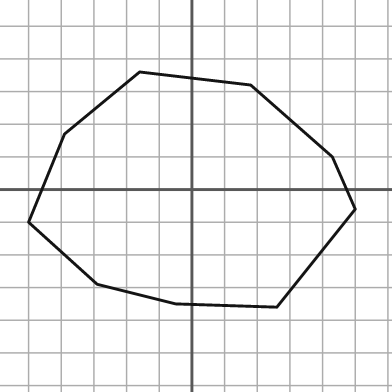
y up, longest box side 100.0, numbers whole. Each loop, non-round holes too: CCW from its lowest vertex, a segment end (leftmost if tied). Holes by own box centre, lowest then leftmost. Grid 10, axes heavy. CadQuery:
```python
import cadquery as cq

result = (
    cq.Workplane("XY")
    .moveTo(26.0, -36.0)
    .lineTo(50.0, -6.0)
    .lineTo(43.0, 10.0)
    .lineTo(18.0, 32.0)
    .lineTo(-16.0, 36.0)
    .lineTo(-39.0, 17.0)
    .lineTo(-50.0, -10.0)
    .lineTo(-29.0, -29.0)
    .lineTo(-5.0, -35.0)
    .close()
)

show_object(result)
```